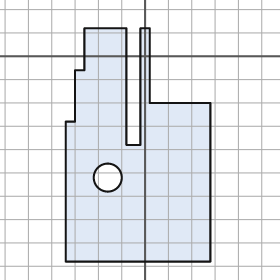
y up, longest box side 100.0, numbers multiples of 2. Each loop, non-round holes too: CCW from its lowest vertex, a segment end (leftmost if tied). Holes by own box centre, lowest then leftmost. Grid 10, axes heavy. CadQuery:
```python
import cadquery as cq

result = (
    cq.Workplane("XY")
    .moveTo(-34.0, -88.0)
    .lineTo(28.0, -88.0)
    .lineTo(28.0, -20.0)
    .lineTo(2.0, -20.0)
    .lineTo(2.0, 12.0)
    .lineTo(-2.0, 12.0)
    .lineTo(-2.0, -38.0)
    .lineTo(-8.0, -38.0)
    .lineTo(-8.0, 12.0)
    .lineTo(-26.0, 12.0)
    .lineTo(-26.0, -6.0)
    .lineTo(-30.0, -6.0)
    .lineTo(-30.0, -28.0)
    .lineTo(-34.0, -28.0)
    .close()
    .moveTo(-16.0, -52.0)
    .circle(6.0)
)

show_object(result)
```